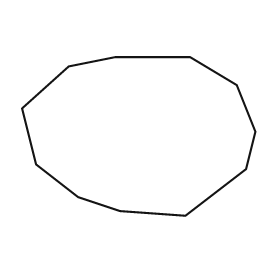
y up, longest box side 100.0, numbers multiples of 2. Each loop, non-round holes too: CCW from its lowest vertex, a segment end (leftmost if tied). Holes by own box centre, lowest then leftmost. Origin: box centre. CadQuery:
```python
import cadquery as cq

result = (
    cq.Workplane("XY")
    .moveTo(20.0, -34.0)
    .lineTo(46.0, -14.0)
    .lineTo(50.0, 2.0)
    .lineTo(42.0, 22.0)
    .lineTo(22.0, 34.0)
    .lineTo(-10.0, 34.0)
    .lineTo(-30.0, 30.0)
    .lineTo(-50.0, 12.0)
    .lineTo(-44.0, -12.0)
    .lineTo(-26.0, -26.0)
    .lineTo(-8.0, -32.0)
    .close()
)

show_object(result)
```